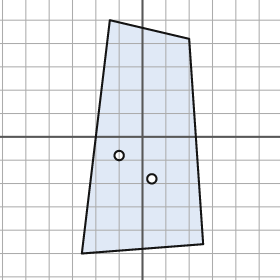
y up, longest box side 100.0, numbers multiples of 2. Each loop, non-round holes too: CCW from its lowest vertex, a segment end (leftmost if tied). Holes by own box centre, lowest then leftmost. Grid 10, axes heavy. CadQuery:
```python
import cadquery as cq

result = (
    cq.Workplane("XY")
    .moveTo(-26.0, -50.0)
    .lineTo(26.0, -46.0)
    .lineTo(20.0, 42.0)
    .lineTo(-14.0, 50.0)
    .close()
    .moveTo(4.0, -18.0)
    .circle(2.0)
    .moveTo(-10.0, -8.0)
    .circle(2.0)
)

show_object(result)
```